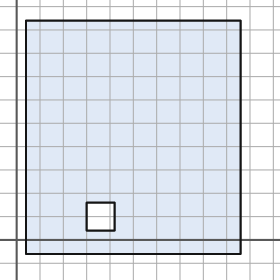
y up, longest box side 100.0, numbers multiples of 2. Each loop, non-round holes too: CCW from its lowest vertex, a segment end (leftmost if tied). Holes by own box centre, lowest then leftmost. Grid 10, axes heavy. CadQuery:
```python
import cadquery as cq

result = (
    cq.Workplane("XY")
    .moveTo(4.0, -6.0)
    .lineTo(96.0, -6.0)
    .lineTo(96.0, 94.0)
    .lineTo(4.0, 94.0)
    .close()
    .moveTo(30.0, 4.0)
    .lineTo(42.0, 4.0)
    .lineTo(42.0, 16.0)
    .lineTo(30.0, 16.0)
    .close()
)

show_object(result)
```